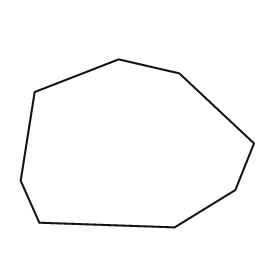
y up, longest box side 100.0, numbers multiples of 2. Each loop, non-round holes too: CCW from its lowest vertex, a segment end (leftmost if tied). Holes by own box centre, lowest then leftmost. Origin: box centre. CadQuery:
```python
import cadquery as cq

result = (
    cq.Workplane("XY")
    .moveTo(16.0, -36.0)
    .lineTo(42.0, -20.0)
    .lineTo(50.0, 0.0)
    .lineTo(18.0, 30.0)
    .lineTo(-8.0, 36.0)
    .lineTo(-44.0, 22.0)
    .lineTo(-50.0, -16.0)
    .lineTo(-42.0, -34.0)
    .close()
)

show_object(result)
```